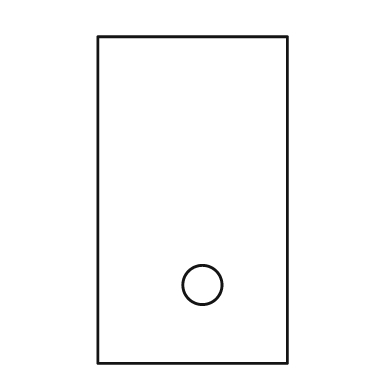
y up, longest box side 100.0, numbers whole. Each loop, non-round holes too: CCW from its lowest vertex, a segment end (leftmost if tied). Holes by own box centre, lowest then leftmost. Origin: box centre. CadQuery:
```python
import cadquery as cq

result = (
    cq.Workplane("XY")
    .moveTo(-29.0, -50.0)
    .lineTo(29.0, -50.0)
    .lineTo(29.0, 50.0)
    .lineTo(-29.0, 50.0)
    .close()
    .moveTo(3.0, -26.0)
    .circle(6.0)
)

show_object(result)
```